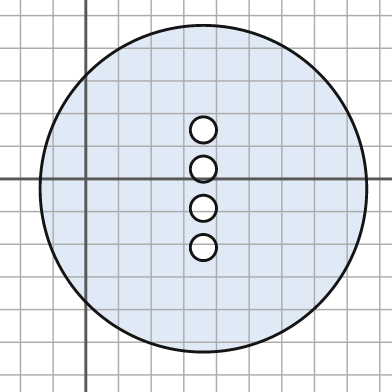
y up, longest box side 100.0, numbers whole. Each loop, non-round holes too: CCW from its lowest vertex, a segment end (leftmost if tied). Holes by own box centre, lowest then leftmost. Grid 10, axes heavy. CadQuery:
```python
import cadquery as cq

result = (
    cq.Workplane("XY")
    .moveTo(36.0, -3.0)
    .circle(50.0)
    .moveTo(36.0, -21.0)
    .circle(4.0)
    .moveTo(36.0, -9.0)
    .circle(4.0)
    .moveTo(36.0, 3.0)
    .circle(4.0)
    .moveTo(36.0, 15.0)
    .circle(4.0)
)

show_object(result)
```